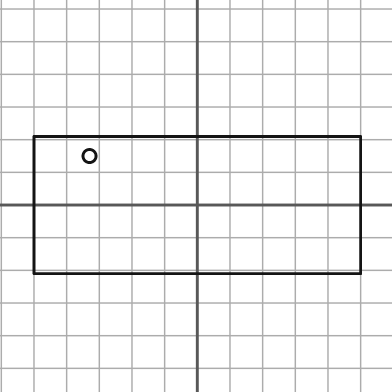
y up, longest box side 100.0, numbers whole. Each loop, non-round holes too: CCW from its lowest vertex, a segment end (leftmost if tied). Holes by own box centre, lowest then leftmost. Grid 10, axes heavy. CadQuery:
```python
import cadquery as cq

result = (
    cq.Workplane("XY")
    .moveTo(-50.0, -21.0)
    .lineTo(50.0, -21.0)
    .lineTo(50.0, 21.0)
    .lineTo(-50.0, 21.0)
    .close()
    .moveTo(-33.0, 15.0)
    .circle(2.0)
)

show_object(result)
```